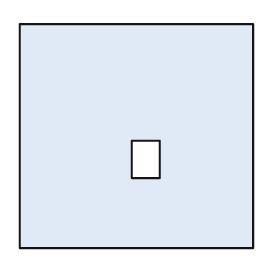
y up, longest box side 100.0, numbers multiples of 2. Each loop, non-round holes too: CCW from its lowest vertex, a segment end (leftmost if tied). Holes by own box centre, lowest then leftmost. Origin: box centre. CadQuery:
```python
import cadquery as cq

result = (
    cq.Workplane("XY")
    .moveTo(-50.0, -48.0)
    .lineTo(50.0, -48.0)
    .lineTo(50.0, 48.0)
    .lineTo(-50.0, 48.0)
    .close()
    .moveTo(-2.0, -18.0)
    .lineTo(10.0, -18.0)
    .lineTo(10.0, -2.0)
    .lineTo(-2.0, -2.0)
    .close()
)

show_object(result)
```